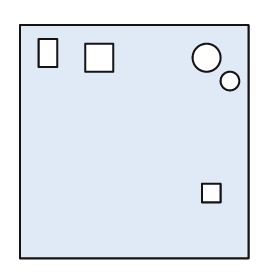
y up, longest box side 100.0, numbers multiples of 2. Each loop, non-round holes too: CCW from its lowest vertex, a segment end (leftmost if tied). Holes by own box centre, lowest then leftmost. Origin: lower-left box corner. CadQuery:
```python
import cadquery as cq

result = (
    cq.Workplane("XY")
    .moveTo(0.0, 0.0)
    .lineTo(98.0, 0.0)
    .lineTo(98.0, 100.0)
    .lineTo(0.0, 100.0)
    .close()
    .moveTo(78.0, 24.0)
    .lineTo(86.0, 24.0)
    .lineTo(86.0, 32.0)
    .lineTo(78.0, 32.0)
    .close()
    .moveTo(90.0, 76.0)
    .circle(4.0)
    .moveTo(28.0, 80.0)
    .lineTo(40.0, 80.0)
    .lineTo(40.0, 92.0)
    .lineTo(28.0, 92.0)
    .close()
    .moveTo(80.0, 86.0)
    .circle(6.0)
    .moveTo(8.0, 82.0)
    .lineTo(16.0, 82.0)
    .lineTo(16.0, 94.0)
    .lineTo(8.0, 94.0)
    .close()
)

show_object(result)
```